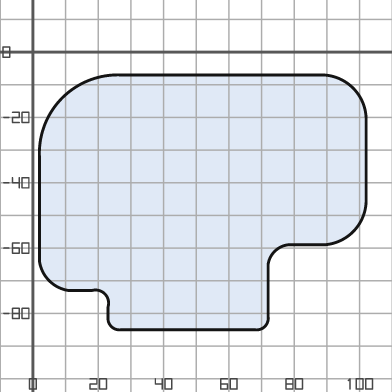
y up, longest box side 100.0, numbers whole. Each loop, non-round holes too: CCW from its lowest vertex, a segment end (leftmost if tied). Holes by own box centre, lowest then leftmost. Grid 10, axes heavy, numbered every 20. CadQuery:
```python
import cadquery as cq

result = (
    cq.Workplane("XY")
    .moveTo(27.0, -85.0)
    .lineTo(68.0, -85.0)
    .threePointArc((71.0, -84.0), (72.0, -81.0))
    .lineTo(72.0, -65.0)
    .threePointArc((74.0, -61.0), (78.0, -59.0))
    .lineTo(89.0, -59.0)
    .threePointArc((98.0, -55.0), (102.0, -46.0))
    .lineTo(102.0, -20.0)
    .threePointArc((98.0, -11.0), (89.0, -7.0))
    .lineTo(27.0, -7.0)
    .threePointArc((9.0, -14.0), (2.0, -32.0))
    .lineTo(2.0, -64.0)
    .threePointArc((5.0, -70.0), (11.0, -73.0))
    .lineTo(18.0, -73.0)
    .threePointArc((22.0, -74.0), (23.0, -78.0))
    .lineTo(23.0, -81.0)
    .threePointArc((24.0, -84.0), (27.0, -85.0))
    .close()
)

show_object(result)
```